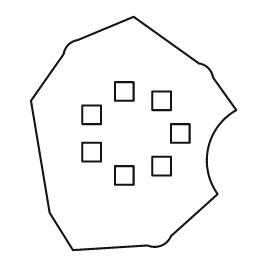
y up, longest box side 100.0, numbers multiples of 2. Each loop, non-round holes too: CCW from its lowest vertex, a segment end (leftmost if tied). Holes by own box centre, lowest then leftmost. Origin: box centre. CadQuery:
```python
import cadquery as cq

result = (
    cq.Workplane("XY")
    .moveTo(-26.0, -50.0)
    .lineTo(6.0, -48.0)
    .threePointArc((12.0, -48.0), (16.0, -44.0))
    .lineTo(36.0, -26.0)
    .threePointArc((32.0, -6.0), (44.0, 10.0))
    .lineTo(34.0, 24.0)
    .threePointArc((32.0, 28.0), (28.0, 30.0))
    .lineTo(0.0, 50.0)
    .lineTo(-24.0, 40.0)
    .threePointArc((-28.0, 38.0), (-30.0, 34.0))
    .lineTo(-44.0, 14.0)
    .lineTo(-36.0, -34.0)
    .close()
    .moveTo(-8.0, -22.0)
    .lineTo(0.0, -22.0)
    .lineTo(0.0, -14.0)
    .lineTo(-8.0, -14.0)
    .close()
    .moveTo(8.0, -18.0)
    .lineTo(16.0, -18.0)
    .lineTo(16.0, -10.0)
    .lineTo(8.0, -10.0)
    .close()
    .moveTo(-22.0, -12.0)
    .lineTo(-14.0, -12.0)
    .lineTo(-14.0, -4.0)
    .lineTo(-22.0, -4.0)
    .close()
    .moveTo(16.0, -4.0)
    .lineTo(24.0, -4.0)
    .lineTo(24.0, 4.0)
    .lineTo(16.0, 4.0)
    .close()
    .moveTo(-22.0, 4.0)
    .lineTo(-14.0, 4.0)
    .lineTo(-14.0, 12.0)
    .lineTo(-22.0, 12.0)
    .close()
    .moveTo(8.0, 10.0)
    .lineTo(16.0, 10.0)
    .lineTo(16.0, 18.0)
    .lineTo(8.0, 18.0)
    .close()
    .moveTo(-8.0, 14.0)
    .lineTo(0.0, 14.0)
    .lineTo(0.0, 22.0)
    .lineTo(-8.0, 22.0)
    .close()
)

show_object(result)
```